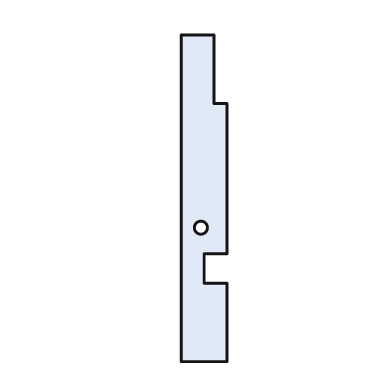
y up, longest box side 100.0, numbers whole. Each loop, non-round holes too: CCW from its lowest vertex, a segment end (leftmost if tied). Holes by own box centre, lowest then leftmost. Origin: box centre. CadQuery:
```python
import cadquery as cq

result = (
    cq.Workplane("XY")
    .moveTo(-7.0, -50.0)
    .lineTo(7.0, -50.0)
    .lineTo(7.0, -26.0)
    .lineTo(0.0, -26.0)
    .lineTo(0.0, -17.0)
    .lineTo(7.0, -17.0)
    .lineTo(7.0, 29.0)
    .lineTo(3.0, 29.0)
    .lineTo(3.0, 50.0)
    .lineTo(-7.0, 50.0)
    .close()
    .moveTo(-1.0, -9.0)
    .circle(2.0)
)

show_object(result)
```